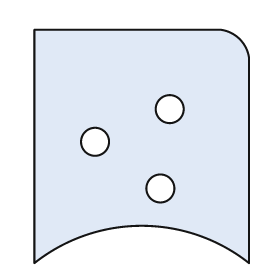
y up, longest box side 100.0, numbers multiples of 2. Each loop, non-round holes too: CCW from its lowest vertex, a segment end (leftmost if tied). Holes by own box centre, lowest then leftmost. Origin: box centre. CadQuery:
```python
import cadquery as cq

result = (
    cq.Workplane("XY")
    .moveTo(-46.0, -50.0)
    .threePointArc((0.0, -34.0), (46.0, -50.0))
    .lineTo(46.0, 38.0)
    .threePointArc((42.0, 46.0), (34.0, 50.0))
    .lineTo(-46.0, 50.0)
    .close()
    .moveTo(8.0, -18.0)
    .circle(6.0)
    .moveTo(-20.0, 2.0)
    .circle(6.0)
    .moveTo(12.0, 16.0)
    .circle(6.0)
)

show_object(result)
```